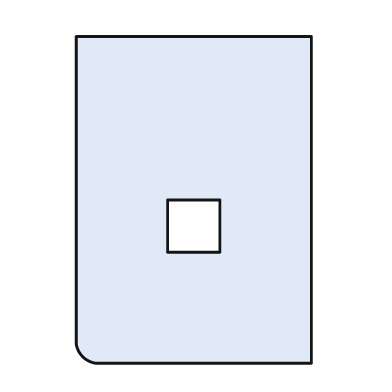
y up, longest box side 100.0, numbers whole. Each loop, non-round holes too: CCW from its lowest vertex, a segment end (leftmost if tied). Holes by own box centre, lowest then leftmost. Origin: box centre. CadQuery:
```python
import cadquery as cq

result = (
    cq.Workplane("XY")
    .moveTo(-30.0, -50.0)
    .lineTo(36.0, -50.0)
    .lineTo(36.0, 50.0)
    .lineTo(-36.0, 50.0)
    .lineTo(-36.0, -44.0)
    .threePointArc((-34.0, -48.0), (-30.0, -50.0))
    .close()
    .moveTo(-8.0, -16.0)
    .lineTo(8.0, -16.0)
    .lineTo(8.0, 0.0)
    .lineTo(-8.0, 0.0)
    .close()
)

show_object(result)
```